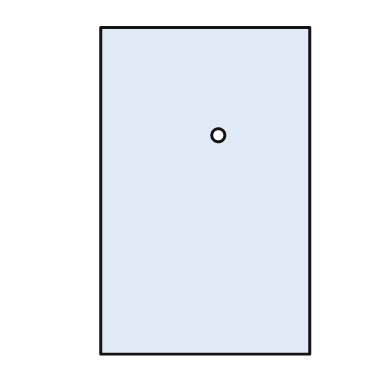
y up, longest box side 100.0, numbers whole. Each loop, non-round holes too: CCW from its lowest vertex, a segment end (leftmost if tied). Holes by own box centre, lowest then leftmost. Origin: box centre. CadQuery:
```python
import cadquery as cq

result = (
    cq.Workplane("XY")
    .moveTo(-32.0, -50.0)
    .lineTo(32.0, -50.0)
    .lineTo(32.0, 50.0)
    .lineTo(-32.0, 50.0)
    .close()
    .moveTo(4.0, 17.0)
    .circle(2.0)
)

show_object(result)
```